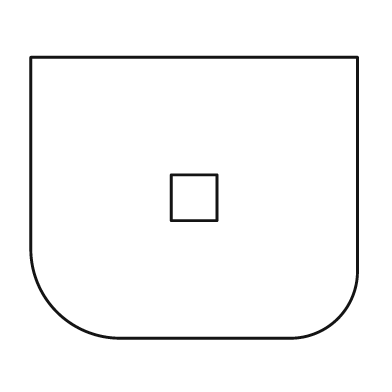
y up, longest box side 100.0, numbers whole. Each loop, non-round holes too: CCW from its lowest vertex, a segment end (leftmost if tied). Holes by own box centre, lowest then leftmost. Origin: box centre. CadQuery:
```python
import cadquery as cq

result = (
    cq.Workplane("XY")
    .moveTo(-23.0, -43.0)
    .lineTo(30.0, -43.0)
    .threePointArc((44.0, -37.0), (50.0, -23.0))
    .lineTo(50.0, 43.0)
    .lineTo(-50.0, 43.0)
    .lineTo(-50.0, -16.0)
    .threePointArc((-42.0, -35.0), (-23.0, -43.0))
    .close()
    .moveTo(-7.0, -7.0)
    .lineTo(7.0, -7.0)
    .lineTo(7.0, 7.0)
    .lineTo(-7.0, 7.0)
    .close()
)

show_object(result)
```